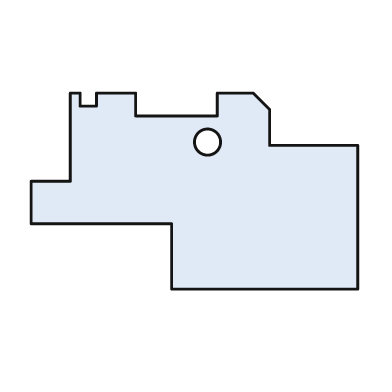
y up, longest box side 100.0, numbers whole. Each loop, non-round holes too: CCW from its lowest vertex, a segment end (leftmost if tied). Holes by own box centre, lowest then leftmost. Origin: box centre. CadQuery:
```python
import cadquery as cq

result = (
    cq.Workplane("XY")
    .moveTo(-7.0, -30.0)
    .lineTo(50.0, -30.0)
    .lineTo(50.0, 14.0)
    .lineTo(23.0, 14.0)
    .lineTo(23.0, 25.0)
    .lineTo(18.0, 30.0)
    .lineTo(7.0, 30.0)
    .lineTo(7.0, 23.0)
    .lineTo(-18.0, 23.0)
    .lineTo(-18.0, 30.0)
    .lineTo(-30.0, 30.0)
    .lineTo(-30.0, 26.0)
    .lineTo(-35.0, 26.0)
    .lineTo(-35.0, 30.0)
    .lineTo(-38.0, 30.0)
    .lineTo(-38.0, 3.0)
    .lineTo(-50.0, 3.0)
    .lineTo(-50.0, -10.0)
    .lineTo(-7.0, -10.0)
    .close()
    .moveTo(4.0, 15.0)
    .circle(4.0)
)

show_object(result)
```